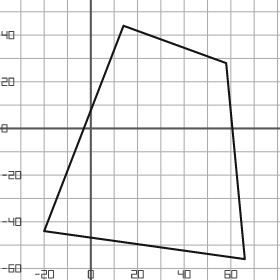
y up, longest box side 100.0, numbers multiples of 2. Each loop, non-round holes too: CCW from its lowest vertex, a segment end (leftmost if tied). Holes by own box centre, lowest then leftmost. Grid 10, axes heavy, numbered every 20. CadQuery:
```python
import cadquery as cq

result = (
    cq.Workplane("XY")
    .moveTo(66.0, -56.0)
    .lineTo(58.0, 28.0)
    .lineTo(14.0, 44.0)
    .lineTo(-20.0, -44.0)
    .close()
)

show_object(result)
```